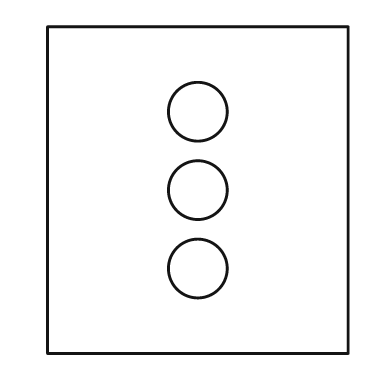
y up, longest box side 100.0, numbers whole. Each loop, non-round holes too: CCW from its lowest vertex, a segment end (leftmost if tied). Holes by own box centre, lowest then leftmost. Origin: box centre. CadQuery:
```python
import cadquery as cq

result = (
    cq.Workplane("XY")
    .moveTo(-46.0, -50.0)
    .lineTo(46.0, -50.0)
    .lineTo(46.0, 50.0)
    .lineTo(-46.0, 50.0)
    .close()
    .moveTo(0.0, -24.0)
    .circle(9.0)
    .moveTo(0.0, 0.0)
    .circle(9.0)
    .moveTo(0.0, 24.0)
    .circle(9.0)
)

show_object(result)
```